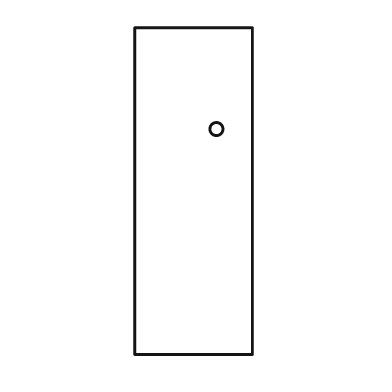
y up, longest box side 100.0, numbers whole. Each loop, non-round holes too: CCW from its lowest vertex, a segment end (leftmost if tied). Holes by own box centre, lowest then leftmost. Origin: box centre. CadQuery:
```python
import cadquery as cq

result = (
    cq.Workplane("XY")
    .moveTo(-18.0, -50.0)
    .lineTo(18.0, -50.0)
    .lineTo(18.0, 50.0)
    .lineTo(-18.0, 50.0)
    .close()
    .moveTo(7.0, 19.0)
    .circle(2.0)
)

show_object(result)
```